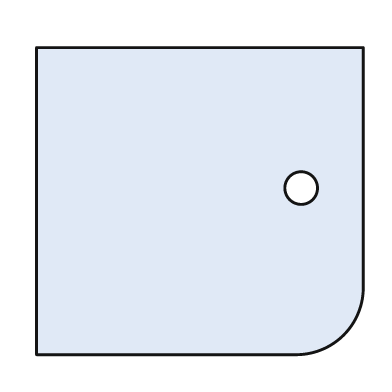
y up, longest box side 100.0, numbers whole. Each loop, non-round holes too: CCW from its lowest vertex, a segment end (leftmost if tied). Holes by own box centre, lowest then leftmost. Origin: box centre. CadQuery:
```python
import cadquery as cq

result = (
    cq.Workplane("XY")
    .moveTo(-50.0, -47.0)
    .lineTo(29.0, -47.0)
    .threePointArc((44.0, -41.0), (50.0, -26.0))
    .lineTo(50.0, 47.0)
    .lineTo(-50.0, 47.0)
    .close()
    .moveTo(31.0, 4.0)
    .circle(5.0)
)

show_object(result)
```